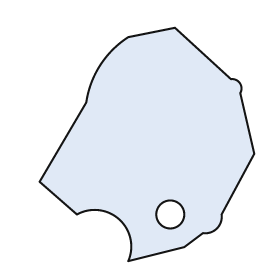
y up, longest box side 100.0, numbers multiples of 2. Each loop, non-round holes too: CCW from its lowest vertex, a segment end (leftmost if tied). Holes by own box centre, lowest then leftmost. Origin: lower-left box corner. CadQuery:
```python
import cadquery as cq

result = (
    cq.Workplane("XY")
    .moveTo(38.0, 0.0)
    .lineTo(62.0, 6.0)
    .lineTo(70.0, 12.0)
    .threePointArc((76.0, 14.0), (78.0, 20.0))
    .lineTo(92.0, 46.0)
    .lineTo(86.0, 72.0)
    .threePointArc((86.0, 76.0), (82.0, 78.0))
    .lineTo(58.0, 100.0)
    .lineTo(38.0, 96.0)
    .threePointArc((26.0, 84.0), (20.0, 68.0))
    .lineTo(0.0, 34.0)
    .lineTo(16.0, 20.0)
    .threePointArc((34.0, 18.0), (38.0, 0.0))
    .close()
    .moveTo(56.0, 20.0)
    .circle(6.0)
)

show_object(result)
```